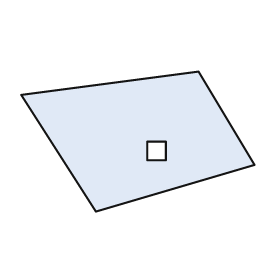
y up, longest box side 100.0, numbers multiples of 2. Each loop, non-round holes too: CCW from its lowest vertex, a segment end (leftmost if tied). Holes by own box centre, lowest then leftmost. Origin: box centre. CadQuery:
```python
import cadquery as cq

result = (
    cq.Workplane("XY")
    .moveTo(-18.0, -30.0)
    .lineTo(50.0, -10.0)
    .lineTo(26.0, 30.0)
    .lineTo(-50.0, 20.0)
    .close()
    .moveTo(4.0, -8.0)
    .lineTo(12.0, -8.0)
    .lineTo(12.0, 0.0)
    .lineTo(4.0, 0.0)
    .close()
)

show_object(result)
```